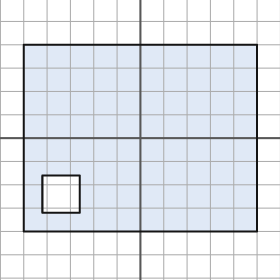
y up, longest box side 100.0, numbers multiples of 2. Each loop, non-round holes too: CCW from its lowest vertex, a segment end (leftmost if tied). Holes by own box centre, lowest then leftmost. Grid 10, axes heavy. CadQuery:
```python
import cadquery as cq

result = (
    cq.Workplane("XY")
    .moveTo(-50.0, -40.0)
    .lineTo(50.0, -40.0)
    .lineTo(50.0, 40.0)
    .lineTo(-50.0, 40.0)
    .close()
    .moveTo(-42.0, -32.0)
    .lineTo(-26.0, -32.0)
    .lineTo(-26.0, -16.0)
    .lineTo(-42.0, -16.0)
    .close()
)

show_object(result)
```